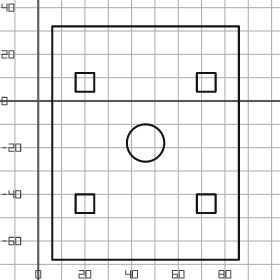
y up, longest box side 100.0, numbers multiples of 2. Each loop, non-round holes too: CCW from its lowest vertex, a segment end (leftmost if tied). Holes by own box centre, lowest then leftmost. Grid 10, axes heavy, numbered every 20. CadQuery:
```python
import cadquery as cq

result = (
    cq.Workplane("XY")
    .moveTo(6.0, -68.0)
    .lineTo(86.0, -68.0)
    .lineTo(86.0, 32.0)
    .lineTo(6.0, 32.0)
    .close()
    .moveTo(16.0, -48.0)
    .lineTo(24.0, -48.0)
    .lineTo(24.0, -40.0)
    .lineTo(16.0, -40.0)
    .close()
    .moveTo(68.0, -48.0)
    .lineTo(76.0, -48.0)
    .lineTo(76.0, -40.0)
    .lineTo(68.0, -40.0)
    .close()
    .moveTo(46.0, -18.0)
    .circle(8.0)
    .moveTo(16.0, 4.0)
    .lineTo(24.0, 4.0)
    .lineTo(24.0, 12.0)
    .lineTo(16.0, 12.0)
    .close()
    .moveTo(68.0, 4.0)
    .lineTo(76.0, 4.0)
    .lineTo(76.0, 12.0)
    .lineTo(68.0, 12.0)
    .close()
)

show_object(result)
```